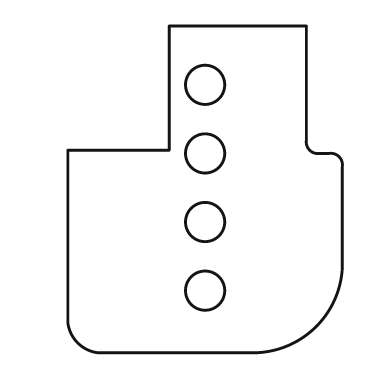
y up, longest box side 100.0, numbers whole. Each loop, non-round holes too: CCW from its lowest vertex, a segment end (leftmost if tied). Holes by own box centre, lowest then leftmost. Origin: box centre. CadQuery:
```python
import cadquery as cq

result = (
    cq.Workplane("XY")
    .moveTo(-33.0, -50.0)
    .lineTo(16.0, -50.0)
    .threePointArc((34.0, -42.0), (42.0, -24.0))
    .lineTo(42.0, 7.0)
    .threePointArc((41.0, 10.0), (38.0, 11.0))
    .lineTo(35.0, 11.0)
    .threePointArc((32.0, 12.0), (31.0, 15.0))
    .lineTo(31.0, 50.0)
    .lineTo(-11.0, 50.0)
    .lineTo(-11.0, 12.0)
    .lineTo(-42.0, 12.0)
    .lineTo(-42.0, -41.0)
    .threePointArc((-39.0, -47.0), (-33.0, -50.0))
    .close()
    .moveTo(0.0, -31.0)
    .circle(6.0)
    .moveTo(0.0, -10.0)
    .circle(6.0)
    .moveTo(0.0, 11.0)
    .circle(6.0)
    .moveTo(0.0, 32.0)
    .circle(6.0)
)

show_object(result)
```